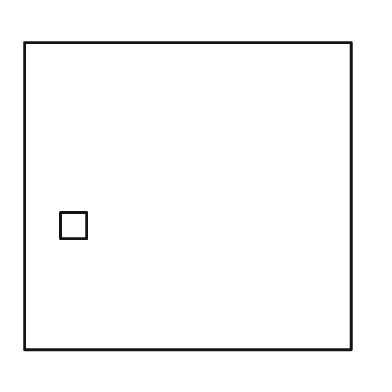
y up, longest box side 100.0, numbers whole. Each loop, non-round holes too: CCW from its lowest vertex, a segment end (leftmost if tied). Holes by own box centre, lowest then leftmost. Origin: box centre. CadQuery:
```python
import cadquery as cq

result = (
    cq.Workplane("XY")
    .moveTo(-50.0, -47.0)
    .lineTo(50.0, -47.0)
    .lineTo(50.0, 47.0)
    .lineTo(-50.0, 47.0)
    .close()
    .moveTo(-39.0, -13.0)
    .lineTo(-31.0, -13.0)
    .lineTo(-31.0, -5.0)
    .lineTo(-39.0, -5.0)
    .close()
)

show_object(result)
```